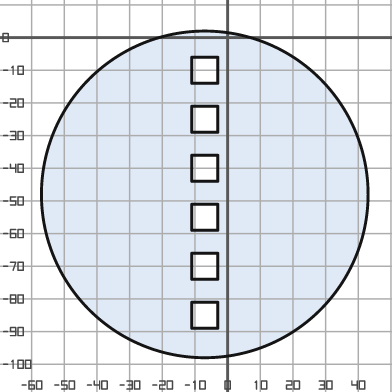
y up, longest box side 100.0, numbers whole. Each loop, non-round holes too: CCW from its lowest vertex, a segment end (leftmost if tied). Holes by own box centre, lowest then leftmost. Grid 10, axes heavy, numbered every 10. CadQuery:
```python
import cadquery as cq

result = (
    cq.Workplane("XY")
    .moveTo(-7.0, -48.0)
    .circle(50.0)
    .moveTo(-11.0, -89.0)
    .lineTo(-3.0, -89.0)
    .lineTo(-3.0, -81.0)
    .lineTo(-11.0, -81.0)
    .close()
    .moveTo(-11.0, -74.0)
    .lineTo(-3.0, -74.0)
    .lineTo(-3.0, -66.0)
    .lineTo(-11.0, -66.0)
    .close()
    .moveTo(-11.0, -59.0)
    .lineTo(-3.0, -59.0)
    .lineTo(-3.0, -51.0)
    .lineTo(-11.0, -51.0)
    .close()
    .moveTo(-11.0, -44.0)
    .lineTo(-3.0, -44.0)
    .lineTo(-3.0, -36.0)
    .lineTo(-11.0, -36.0)
    .close()
    .moveTo(-11.0, -29.0)
    .lineTo(-3.0, -29.0)
    .lineTo(-3.0, -21.0)
    .lineTo(-11.0, -21.0)
    .close()
    .moveTo(-11.0, -14.0)
    .lineTo(-3.0, -14.0)
    .lineTo(-3.0, -6.0)
    .lineTo(-11.0, -6.0)
    .close()
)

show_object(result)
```